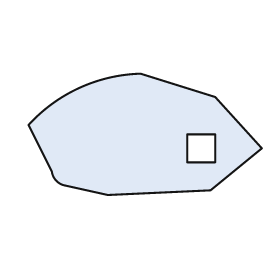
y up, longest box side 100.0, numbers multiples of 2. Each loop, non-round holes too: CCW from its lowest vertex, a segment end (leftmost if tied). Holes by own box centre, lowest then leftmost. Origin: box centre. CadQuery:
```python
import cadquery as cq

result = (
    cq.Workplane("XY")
    .moveTo(-16.0, -26.0)
    .lineTo(28.0, -24.0)
    .lineTo(50.0, -6.0)
    .lineTo(30.0, 16.0)
    .lineTo(-2.0, 26.0)
    .threePointArc((-28.0, 20.0), (-50.0, 4.0))
    .lineTo(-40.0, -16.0)
    .threePointArc((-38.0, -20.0), (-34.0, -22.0))
    .close()
    .moveTo(18.0, -12.0)
    .lineTo(30.0, -12.0)
    .lineTo(30.0, 0.0)
    .lineTo(18.0, 0.0)
    .close()
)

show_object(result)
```